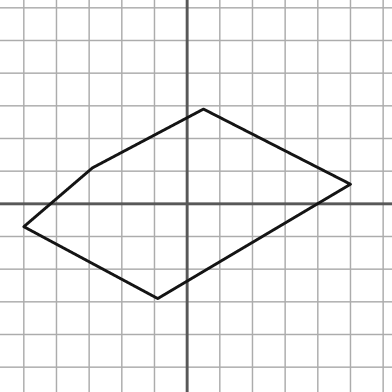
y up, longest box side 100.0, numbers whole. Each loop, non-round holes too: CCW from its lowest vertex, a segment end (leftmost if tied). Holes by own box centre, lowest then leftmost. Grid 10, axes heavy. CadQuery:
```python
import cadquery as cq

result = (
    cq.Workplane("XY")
    .moveTo(-9.0, -29.0)
    .lineTo(50.0, 6.0)
    .lineTo(5.0, 29.0)
    .lineTo(-29.0, 11.0)
    .lineTo(-50.0, -7.0)
    .close()
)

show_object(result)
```